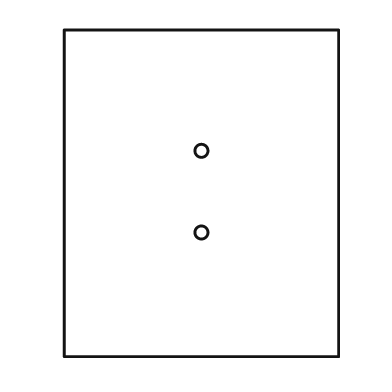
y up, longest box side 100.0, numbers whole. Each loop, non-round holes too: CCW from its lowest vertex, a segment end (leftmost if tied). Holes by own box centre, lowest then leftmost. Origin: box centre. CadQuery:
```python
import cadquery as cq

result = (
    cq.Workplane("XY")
    .moveTo(-42.0, -50.0)
    .lineTo(42.0, -50.0)
    .lineTo(42.0, 50.0)
    .lineTo(-42.0, 50.0)
    .close()
    .moveTo(0.0, -12.0)
    .circle(2.0)
    .moveTo(0.0, 13.0)
    .circle(2.0)
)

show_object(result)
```